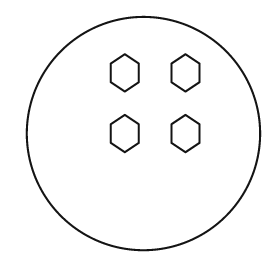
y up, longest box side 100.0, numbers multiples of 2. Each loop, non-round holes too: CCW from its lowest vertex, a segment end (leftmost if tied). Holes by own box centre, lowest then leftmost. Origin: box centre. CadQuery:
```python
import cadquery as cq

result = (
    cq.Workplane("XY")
    .moveTo(0.0, 0.0)
    .circle(50.0)
    .moveTo(-8.0, -8.0)
    .lineTo(-2.0, -4.0)
    .lineTo(-2.0, 4.0)
    .lineTo(-8.0, 8.0)
    .lineTo(-14.0, 4.0)
    .lineTo(-14.0, -4.0)
    .close()
    .moveTo(18.0, -8.0)
    .lineTo(24.0, -4.0)
    .lineTo(24.0, 4.0)
    .lineTo(18.0, 8.0)
    .lineTo(12.0, 4.0)
    .lineTo(12.0, -4.0)
    .close()
    .moveTo(-8.0, 18.0)
    .lineTo(-2.0, 22.0)
    .lineTo(-2.0, 30.0)
    .lineTo(-8.0, 34.0)
    .lineTo(-14.0, 30.0)
    .lineTo(-14.0, 22.0)
    .close()
    .moveTo(18.0, 18.0)
    .lineTo(24.0, 22.0)
    .lineTo(24.0, 30.0)
    .lineTo(18.0, 34.0)
    .lineTo(12.0, 30.0)
    .lineTo(12.0, 22.0)
    .close()
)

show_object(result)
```